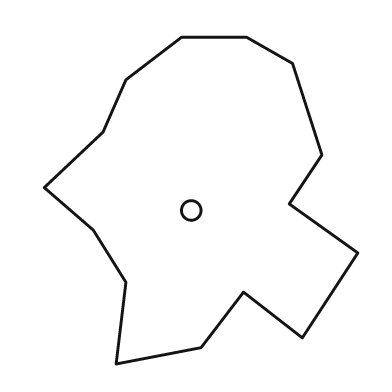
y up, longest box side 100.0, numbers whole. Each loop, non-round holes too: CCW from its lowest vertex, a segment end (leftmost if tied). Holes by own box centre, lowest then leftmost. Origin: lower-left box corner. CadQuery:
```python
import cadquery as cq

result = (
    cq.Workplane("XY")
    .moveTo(22.0, 0.0)
    .lineTo(48.0, 5.0)
    .lineTo(61.0, 22.0)
    .lineTo(79.0, 8.0)
    .lineTo(96.0, 34.0)
    .lineTo(75.0, 49.0)
    .lineTo(85.0, 64.0)
    .lineTo(76.0, 92.0)
    .lineTo(62.0, 100.0)
    .lineTo(42.0, 100.0)
    .lineTo(25.0, 87.0)
    .lineTo(18.0, 71.0)
    .lineTo(0.0, 54.0)
    .lineTo(15.0, 41.0)
    .lineTo(25.0, 25.0)
    .close()
    .moveTo(45.0, 47.0)
    .circle(3.0)
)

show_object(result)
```